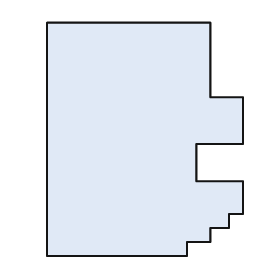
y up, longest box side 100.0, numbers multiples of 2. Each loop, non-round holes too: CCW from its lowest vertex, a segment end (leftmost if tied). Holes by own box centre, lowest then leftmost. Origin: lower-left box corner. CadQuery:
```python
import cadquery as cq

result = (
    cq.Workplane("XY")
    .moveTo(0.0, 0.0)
    .lineTo(60.0, 0.0)
    .lineTo(60.0, 6.0)
    .lineTo(70.0, 6.0)
    .lineTo(70.0, 12.0)
    .lineTo(78.0, 12.0)
    .lineTo(78.0, 18.0)
    .lineTo(84.0, 18.0)
    .lineTo(84.0, 32.0)
    .lineTo(64.0, 32.0)
    .lineTo(64.0, 48.0)
    .lineTo(84.0, 48.0)
    .lineTo(84.0, 68.0)
    .lineTo(70.0, 68.0)
    .lineTo(70.0, 100.0)
    .lineTo(0.0, 100.0)
    .close()
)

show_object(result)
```